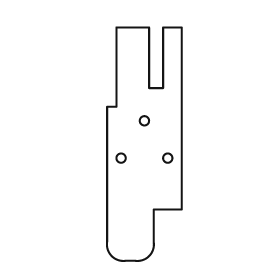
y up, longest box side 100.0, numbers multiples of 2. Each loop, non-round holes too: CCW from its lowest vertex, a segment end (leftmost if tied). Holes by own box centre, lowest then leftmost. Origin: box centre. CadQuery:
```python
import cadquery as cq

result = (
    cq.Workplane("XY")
    .moveTo(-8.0, -50.0)
    .lineTo(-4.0, -50.0)
    .threePointArc((2.0, -48.0), (4.0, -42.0))
    .lineTo(4.0, -28.0)
    .lineTo(16.0, -28.0)
    .lineTo(16.0, 50.0)
    .lineTo(8.0, 50.0)
    .lineTo(8.0, 24.0)
    .lineTo(2.0, 24.0)
    .lineTo(2.0, 50.0)
    .lineTo(-12.0, 50.0)
    .lineTo(-12.0, 16.0)
    .lineTo(-16.0, 16.0)
    .lineTo(-16.0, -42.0)
    .threePointArc((-14.0, -48.0), (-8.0, -50.0))
    .close()
    .moveTo(-10.0, -6.0)
    .circle(2.0)
    .moveTo(10.0, -6.0)
    .circle(2.0)
    .moveTo(0.0, 10.0)
    .circle(2.0)
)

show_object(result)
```